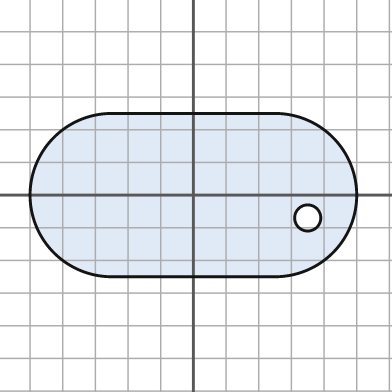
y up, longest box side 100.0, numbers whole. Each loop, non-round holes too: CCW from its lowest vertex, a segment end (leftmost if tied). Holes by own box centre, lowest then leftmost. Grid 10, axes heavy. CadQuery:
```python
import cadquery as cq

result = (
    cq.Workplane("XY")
    .moveTo(-25.0, -25.0)
    .lineTo(25.0, -25.0)
    .threePointArc((50.0, 0.0), (25.0, 25.0))
    .lineTo(-25.0, 25.0)
    .threePointArc((-50.0, 0.0), (-25.0, -25.0))
    .close()
    .moveTo(35.0, -7.0)
    .circle(4.0)
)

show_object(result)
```